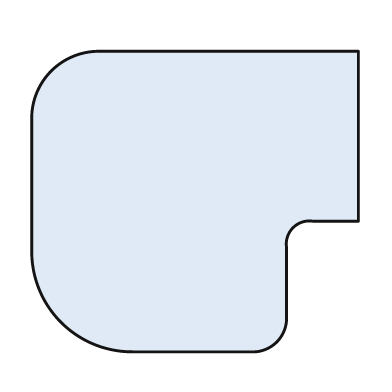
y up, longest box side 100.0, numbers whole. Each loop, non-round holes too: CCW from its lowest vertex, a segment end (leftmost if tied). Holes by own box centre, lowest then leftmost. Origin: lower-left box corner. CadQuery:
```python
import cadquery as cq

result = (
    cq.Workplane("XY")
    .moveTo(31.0, 0.0)
    .lineTo(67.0, 0.0)
    .threePointArc((75.0, 3.0), (78.0, 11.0))
    .lineTo(78.0, 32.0)
    .threePointArc((80.0, 38.0), (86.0, 40.0))
    .lineTo(100.0, 40.0)
    .lineTo(100.0, 92.0)
    .lineTo(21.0, 92.0)
    .threePointArc((6.0, 86.0), (0.0, 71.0))
    .lineTo(0.0, 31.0)
    .threePointArc((9.0, 9.0), (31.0, 0.0))
    .close()
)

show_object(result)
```